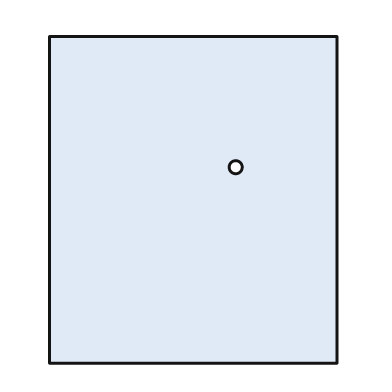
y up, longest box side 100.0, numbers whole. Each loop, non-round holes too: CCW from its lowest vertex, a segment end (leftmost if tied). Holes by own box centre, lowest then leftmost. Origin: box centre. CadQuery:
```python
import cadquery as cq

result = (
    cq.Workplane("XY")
    .moveTo(-44.0, -50.0)
    .lineTo(44.0, -50.0)
    .lineTo(44.0, 50.0)
    .lineTo(-44.0, 50.0)
    .close()
    .moveTo(13.0, 10.0)
    .circle(2.0)
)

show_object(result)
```